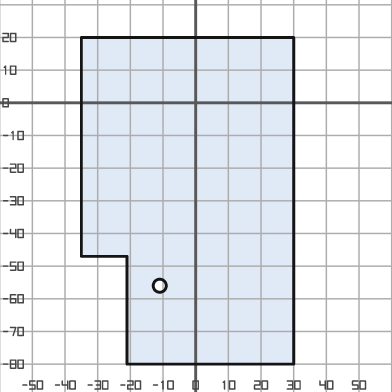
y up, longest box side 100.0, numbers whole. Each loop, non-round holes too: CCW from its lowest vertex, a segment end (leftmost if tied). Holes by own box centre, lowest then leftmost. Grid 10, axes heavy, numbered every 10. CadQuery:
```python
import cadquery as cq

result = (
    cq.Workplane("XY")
    .moveTo(-21.0, -80.0)
    .lineTo(30.0, -80.0)
    .lineTo(30.0, 20.0)
    .lineTo(-35.0, 20.0)
    .lineTo(-35.0, -47.0)
    .lineTo(-21.0, -47.0)
    .close()
    .moveTo(-11.0, -56.0)
    .circle(2.0)
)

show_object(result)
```